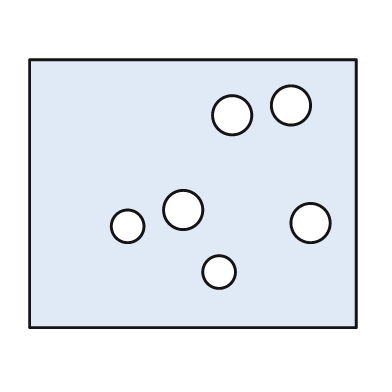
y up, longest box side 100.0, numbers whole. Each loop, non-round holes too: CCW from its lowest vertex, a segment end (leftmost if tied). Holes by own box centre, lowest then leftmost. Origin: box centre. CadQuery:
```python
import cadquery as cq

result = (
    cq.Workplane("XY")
    .moveTo(-50.0, -41.0)
    .lineTo(50.0, -41.0)
    .lineTo(50.0, 41.0)
    .lineTo(-50.0, 41.0)
    .close()
    .moveTo(8.0, -24.0)
    .circle(5.0)
    .moveTo(-20.0, -10.0)
    .circle(5.0)
    .moveTo(36.0, -9.0)
    .circle(6.0)
    .moveTo(-3.0, -5.0)
    .circle(6.0)
    .moveTo(12.0, 24.0)
    .circle(6.0)
    .moveTo(30.0, 27.0)
    .circle(6.0)
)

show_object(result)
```